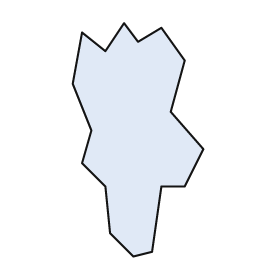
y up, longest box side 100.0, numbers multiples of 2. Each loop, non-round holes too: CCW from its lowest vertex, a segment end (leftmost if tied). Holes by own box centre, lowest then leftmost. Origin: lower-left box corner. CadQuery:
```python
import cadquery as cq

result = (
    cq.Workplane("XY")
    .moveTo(26.0, 0.0)
    .lineTo(34.0, 2.0)
    .lineTo(38.0, 30.0)
    .lineTo(48.0, 30.0)
    .lineTo(56.0, 46.0)
    .lineTo(42.0, 62.0)
    .lineTo(48.0, 84.0)
    .lineTo(38.0, 98.0)
    .lineTo(28.0, 92.0)
    .lineTo(22.0, 100.0)
    .lineTo(14.0, 88.0)
    .lineTo(4.0, 96.0)
    .lineTo(0.0, 74.0)
    .lineTo(8.0, 54.0)
    .lineTo(4.0, 40.0)
    .lineTo(14.0, 30.0)
    .lineTo(16.0, 10.0)
    .close()
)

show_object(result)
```